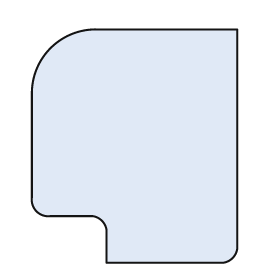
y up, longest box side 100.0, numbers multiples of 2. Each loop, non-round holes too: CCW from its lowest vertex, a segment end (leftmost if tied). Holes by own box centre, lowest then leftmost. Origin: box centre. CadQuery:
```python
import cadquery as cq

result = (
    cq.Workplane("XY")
    .moveTo(-12.0, -50.0)
    .lineTo(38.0, -50.0)
    .threePointArc((42.0, -48.0), (44.0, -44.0))
    .lineTo(44.0, 50.0)
    .lineTo(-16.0, 50.0)
    .threePointArc((-36.0, 42.0), (-44.0, 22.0))
    .lineTo(-44.0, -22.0)
    .threePointArc((-42.0, -28.0), (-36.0, -30.0))
    .lineTo(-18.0, -30.0)
    .threePointArc((-14.0, -32.0), (-12.0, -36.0))
    .close()
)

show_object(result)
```